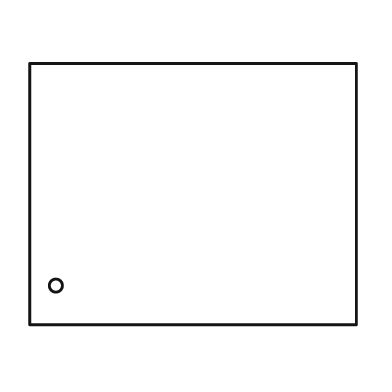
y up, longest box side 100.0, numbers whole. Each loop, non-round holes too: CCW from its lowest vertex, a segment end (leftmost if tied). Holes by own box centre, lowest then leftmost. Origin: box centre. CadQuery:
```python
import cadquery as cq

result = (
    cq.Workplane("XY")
    .moveTo(-50.0, -40.0)
    .lineTo(50.0, -40.0)
    .lineTo(50.0, 40.0)
    .lineTo(-50.0, 40.0)
    .close()
    .moveTo(-42.0, -28.0)
    .circle(2.0)
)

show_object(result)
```